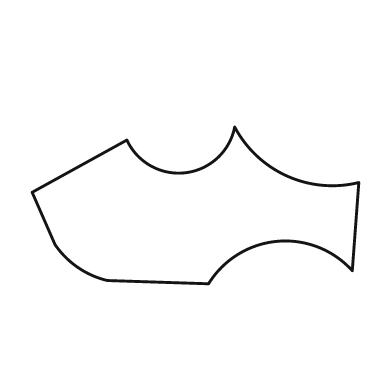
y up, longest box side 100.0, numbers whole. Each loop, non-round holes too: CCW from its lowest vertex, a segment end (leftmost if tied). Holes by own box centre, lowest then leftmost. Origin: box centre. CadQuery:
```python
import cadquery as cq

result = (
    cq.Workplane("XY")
    .moveTo(4.0, -24.0)
    .threePointArc((25.0, -11.0), (48.0, -20.0))
    .lineTo(50.0, 7.0)
    .threePointArc((28.0, 9.0), (12.0, 24.0))
    .threePointArc((-3.0, 10.0), (-21.0, 20.0))
    .lineTo(-50.0, 4.0)
    .lineTo(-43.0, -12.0)
    .threePointArc((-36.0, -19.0), (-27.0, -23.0))
    .close()
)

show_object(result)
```